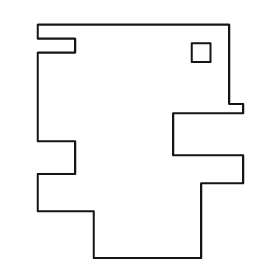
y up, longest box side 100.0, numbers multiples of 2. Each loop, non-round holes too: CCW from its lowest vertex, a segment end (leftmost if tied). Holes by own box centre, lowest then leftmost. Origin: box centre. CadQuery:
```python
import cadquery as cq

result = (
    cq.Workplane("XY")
    .moveTo(-20.0, -50.0)
    .lineTo(26.0, -50.0)
    .lineTo(26.0, -18.0)
    .lineTo(44.0, -18.0)
    .lineTo(44.0, -6.0)
    .lineTo(14.0, -6.0)
    .lineTo(14.0, 12.0)
    .lineTo(44.0, 12.0)
    .lineTo(44.0, 16.0)
    .lineTo(38.0, 16.0)
    .lineTo(38.0, 50.0)
    .lineTo(-44.0, 50.0)
    .lineTo(-44.0, 44.0)
    .lineTo(-28.0, 44.0)
    .lineTo(-28.0, 38.0)
    .lineTo(-44.0, 38.0)
    .lineTo(-44.0, 0.0)
    .lineTo(-28.0, 0.0)
    .lineTo(-28.0, -14.0)
    .lineTo(-44.0, -14.0)
    .lineTo(-44.0, -30.0)
    .lineTo(-20.0, -30.0)
    .close()
    .moveTo(22.0, 34.0)
    .lineTo(30.0, 34.0)
    .lineTo(30.0, 42.0)
    .lineTo(22.0, 42.0)
    .close()
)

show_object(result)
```